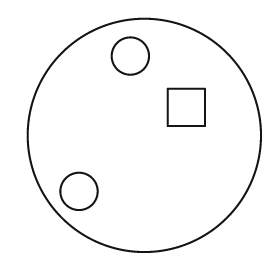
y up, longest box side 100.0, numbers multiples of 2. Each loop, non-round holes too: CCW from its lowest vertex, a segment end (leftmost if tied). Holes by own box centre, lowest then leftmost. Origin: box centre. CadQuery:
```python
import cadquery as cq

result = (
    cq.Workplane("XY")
    .moveTo(0.0, 0.0)
    .circle(50.0)
    .moveTo(-28.0, -24.0)
    .circle(8.0)
    .moveTo(10.0, 4.0)
    .lineTo(26.0, 4.0)
    .lineTo(26.0, 20.0)
    .lineTo(10.0, 20.0)
    .close()
    .moveTo(-6.0, 34.0)
    .circle(8.0)
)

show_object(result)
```